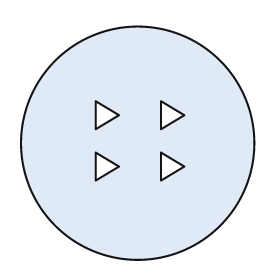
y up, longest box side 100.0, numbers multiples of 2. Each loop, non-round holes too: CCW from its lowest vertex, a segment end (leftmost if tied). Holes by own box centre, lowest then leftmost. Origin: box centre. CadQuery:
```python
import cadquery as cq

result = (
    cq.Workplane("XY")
    .moveTo(0.0, 0.0)
    .circle(50.0)
    .moveTo(-18.0, -16.0)
    .lineTo(-8.0, -10.0)
    .lineTo(-18.0, -4.0)
    .close()
    .moveTo(10.0, -16.0)
    .lineTo(20.0, -10.0)
    .lineTo(10.0, -4.0)
    .close()
    .moveTo(-18.0, 6.0)
    .lineTo(-8.0, 12.0)
    .lineTo(-18.0, 18.0)
    .close()
    .moveTo(10.0, 6.0)
    .lineTo(20.0, 12.0)
    .lineTo(10.0, 18.0)
    .close()
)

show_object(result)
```